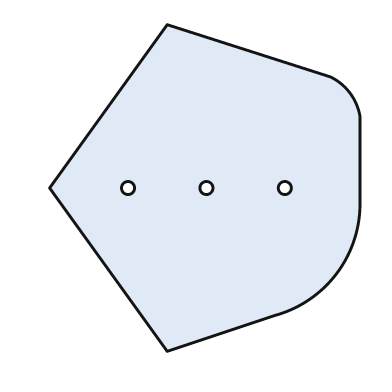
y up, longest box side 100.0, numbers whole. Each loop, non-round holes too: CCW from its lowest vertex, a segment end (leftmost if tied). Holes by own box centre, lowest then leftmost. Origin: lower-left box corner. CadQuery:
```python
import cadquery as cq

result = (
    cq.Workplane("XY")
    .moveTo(36.0, 0.0)
    .lineTo(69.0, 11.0)
    .threePointArc((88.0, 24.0), (95.0, 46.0))
    .lineTo(95.0, 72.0)
    .threePointArc((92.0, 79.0), (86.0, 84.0))
    .lineTo(36.0, 100.0)
    .lineTo(0.0, 50.0)
    .close()
    .moveTo(24.0, 50.0)
    .circle(2.0)
    .moveTo(48.0, 50.0)
    .circle(2.0)
    .moveTo(72.0, 50.0)
    .circle(2.0)
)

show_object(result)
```